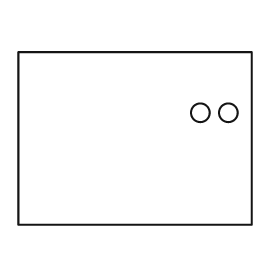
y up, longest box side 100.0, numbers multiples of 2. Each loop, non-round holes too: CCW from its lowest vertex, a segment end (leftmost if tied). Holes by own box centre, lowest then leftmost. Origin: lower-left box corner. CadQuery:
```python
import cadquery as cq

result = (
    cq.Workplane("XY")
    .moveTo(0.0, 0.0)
    .lineTo(100.0, 0.0)
    .lineTo(100.0, 74.0)
    .lineTo(0.0, 74.0)
    .close()
    .moveTo(78.0, 48.0)
    .circle(4.0)
    .moveTo(90.0, 48.0)
    .circle(4.0)
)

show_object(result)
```